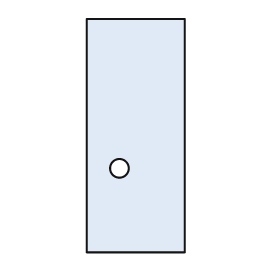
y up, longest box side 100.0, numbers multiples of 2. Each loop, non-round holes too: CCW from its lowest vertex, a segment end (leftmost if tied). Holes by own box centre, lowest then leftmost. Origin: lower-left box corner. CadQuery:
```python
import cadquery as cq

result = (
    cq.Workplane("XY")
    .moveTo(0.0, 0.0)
    .lineTo(42.0, 0.0)
    .lineTo(42.0, 100.0)
    .lineTo(0.0, 100.0)
    .close()
    .moveTo(14.0, 36.0)
    .circle(4.0)
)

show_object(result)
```